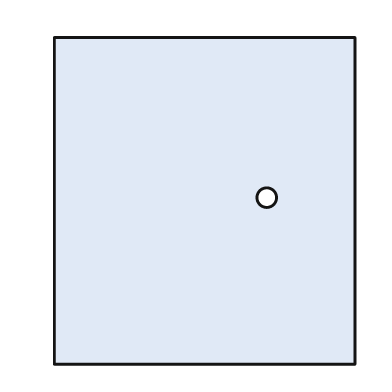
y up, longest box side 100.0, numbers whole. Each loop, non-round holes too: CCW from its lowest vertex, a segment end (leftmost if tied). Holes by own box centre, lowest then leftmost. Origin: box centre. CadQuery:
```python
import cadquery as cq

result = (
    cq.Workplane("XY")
    .moveTo(-46.0, -50.0)
    .lineTo(46.0, -50.0)
    .lineTo(46.0, 50.0)
    .lineTo(-46.0, 50.0)
    .close()
    .moveTo(19.0, 1.0)
    .circle(3.0)
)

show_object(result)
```